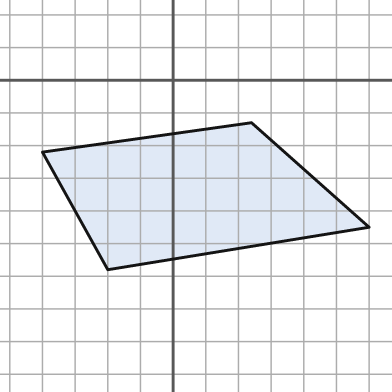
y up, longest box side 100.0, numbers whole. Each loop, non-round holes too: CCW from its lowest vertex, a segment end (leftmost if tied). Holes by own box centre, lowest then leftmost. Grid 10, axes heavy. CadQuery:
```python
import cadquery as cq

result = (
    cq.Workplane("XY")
    .moveTo(-20.0, -58.0)
    .lineTo(60.0, -45.0)
    .lineTo(24.0, -13.0)
    .lineTo(-40.0, -22.0)
    .close()
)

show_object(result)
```